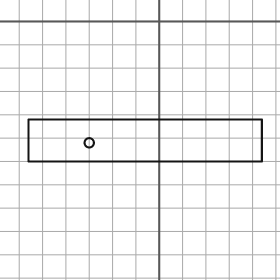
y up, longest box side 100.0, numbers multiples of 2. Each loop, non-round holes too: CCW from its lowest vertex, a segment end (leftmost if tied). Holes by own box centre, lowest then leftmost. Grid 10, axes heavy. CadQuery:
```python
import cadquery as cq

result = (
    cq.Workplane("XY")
    .moveTo(-56.0, -60.0)
    .lineTo(44.0, -60.0)
    .lineTo(44.0, -42.0)
    .lineTo(-56.0, -42.0)
    .close()
    .moveTo(-30.0, -52.0)
    .circle(2.0)
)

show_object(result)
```